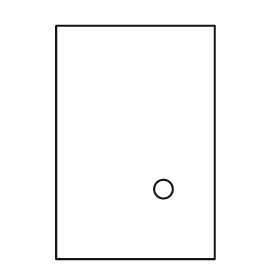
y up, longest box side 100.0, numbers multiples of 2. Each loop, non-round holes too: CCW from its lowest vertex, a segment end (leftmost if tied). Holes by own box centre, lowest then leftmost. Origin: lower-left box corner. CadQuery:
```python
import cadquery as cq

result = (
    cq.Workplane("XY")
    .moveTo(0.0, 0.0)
    .lineTo(68.0, 0.0)
    .lineTo(68.0, 100.0)
    .lineTo(0.0, 100.0)
    .close()
    .moveTo(46.0, 30.0)
    .circle(4.0)
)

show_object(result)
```